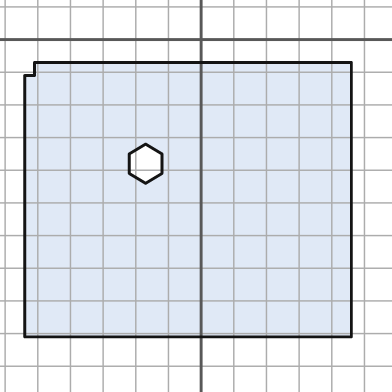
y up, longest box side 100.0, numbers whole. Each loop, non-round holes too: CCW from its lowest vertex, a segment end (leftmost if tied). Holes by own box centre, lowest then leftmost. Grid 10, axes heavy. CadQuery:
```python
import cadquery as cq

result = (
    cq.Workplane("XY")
    .moveTo(-54.0, -91.0)
    .lineTo(46.0, -91.0)
    .lineTo(46.0, -7.0)
    .lineTo(-51.0, -7.0)
    .lineTo(-51.0, -11.0)
    .lineTo(-54.0, -11.0)
    .close()
    .moveTo(-17.0, -44.0)
    .lineTo(-12.0, -41.0)
    .lineTo(-12.0, -35.0)
    .lineTo(-17.0, -32.0)
    .lineTo(-22.0, -35.0)
    .lineTo(-22.0, -41.0)
    .close()
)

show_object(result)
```